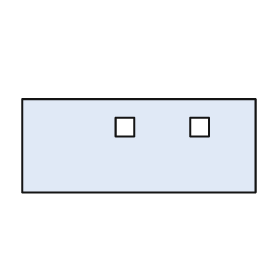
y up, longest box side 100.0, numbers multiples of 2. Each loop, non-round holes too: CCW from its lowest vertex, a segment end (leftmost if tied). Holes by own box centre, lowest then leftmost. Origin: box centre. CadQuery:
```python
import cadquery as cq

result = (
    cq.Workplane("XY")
    .moveTo(-50.0, -20.0)
    .lineTo(50.0, -20.0)
    .lineTo(50.0, 20.0)
    .lineTo(-50.0, 20.0)
    .close()
    .moveTo(-10.0, 4.0)
    .lineTo(-2.0, 4.0)
    .lineTo(-2.0, 12.0)
    .lineTo(-10.0, 12.0)
    .close()
    .moveTo(22.0, 4.0)
    .lineTo(30.0, 4.0)
    .lineTo(30.0, 12.0)
    .lineTo(22.0, 12.0)
    .close()
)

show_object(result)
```